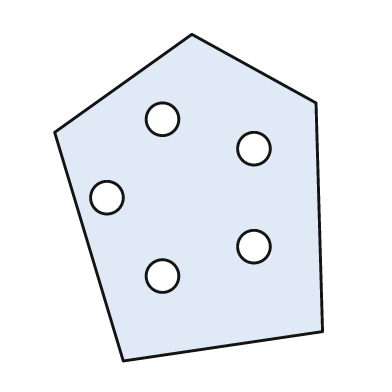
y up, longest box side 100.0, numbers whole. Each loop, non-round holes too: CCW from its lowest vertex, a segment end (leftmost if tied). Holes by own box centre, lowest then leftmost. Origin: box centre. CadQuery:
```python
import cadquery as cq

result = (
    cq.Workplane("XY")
    .moveTo(-20.0, -50.0)
    .lineTo(41.0, -41.0)
    .lineTo(39.0, 29.0)
    .lineTo(1.0, 50.0)
    .lineTo(-41.0, 20.0)
    .close()
    .moveTo(-8.0, -24.0)
    .circle(5.0)
    .moveTo(20.0, -15.0)
    .circle(5.0)
    .moveTo(-25.0, 0.0)
    .circle(5.0)
    .moveTo(20.0, 15.0)
    .circle(5.0)
    .moveTo(-8.0, 24.0)
    .circle(5.0)
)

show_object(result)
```